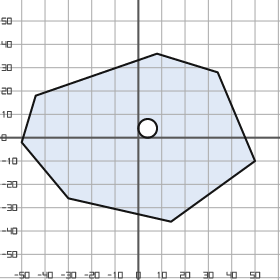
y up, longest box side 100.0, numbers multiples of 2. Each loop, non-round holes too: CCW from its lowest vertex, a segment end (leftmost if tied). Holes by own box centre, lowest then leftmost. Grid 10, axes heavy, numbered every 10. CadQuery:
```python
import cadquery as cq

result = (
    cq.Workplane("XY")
    .moveTo(14.0, -36.0)
    .lineTo(50.0, -10.0)
    .lineTo(34.0, 28.0)
    .lineTo(8.0, 36.0)
    .lineTo(-44.0, 18.0)
    .lineTo(-50.0, -2.0)
    .lineTo(-30.0, -26.0)
    .close()
    .moveTo(4.0, 4.0)
    .circle(4.0)
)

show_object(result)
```